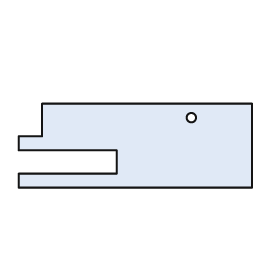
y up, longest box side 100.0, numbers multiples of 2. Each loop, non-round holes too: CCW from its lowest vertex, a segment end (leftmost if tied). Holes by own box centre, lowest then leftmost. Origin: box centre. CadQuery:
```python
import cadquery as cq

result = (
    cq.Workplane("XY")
    .moveTo(-50.0, -18.0)
    .lineTo(50.0, -18.0)
    .lineTo(50.0, 18.0)
    .lineTo(-40.0, 18.0)
    .lineTo(-40.0, 4.0)
    .lineTo(-50.0, 4.0)
    .lineTo(-50.0, -2.0)
    .lineTo(-8.0, -2.0)
    .lineTo(-8.0, -12.0)
    .lineTo(-50.0, -12.0)
    .close()
    .moveTo(24.0, 12.0)
    .circle(2.0)
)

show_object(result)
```